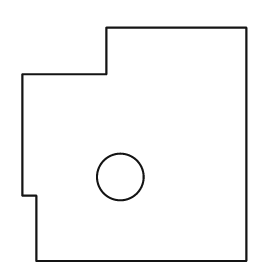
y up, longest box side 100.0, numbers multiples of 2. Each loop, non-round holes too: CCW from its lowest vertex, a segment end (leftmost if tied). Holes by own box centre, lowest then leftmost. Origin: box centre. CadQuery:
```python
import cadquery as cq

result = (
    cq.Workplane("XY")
    .moveTo(-42.0, -50.0)
    .lineTo(48.0, -50.0)
    .lineTo(48.0, 50.0)
    .lineTo(-12.0, 50.0)
    .lineTo(-12.0, 30.0)
    .lineTo(-48.0, 30.0)
    .lineTo(-48.0, -22.0)
    .lineTo(-42.0, -22.0)
    .close()
    .moveTo(-6.0, -14.0)
    .circle(10.0)
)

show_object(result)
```